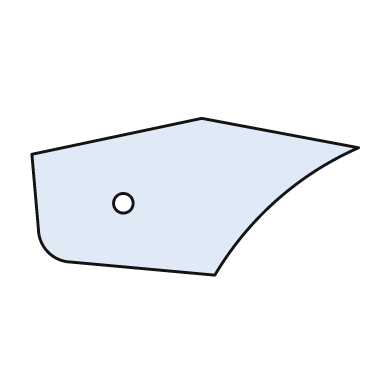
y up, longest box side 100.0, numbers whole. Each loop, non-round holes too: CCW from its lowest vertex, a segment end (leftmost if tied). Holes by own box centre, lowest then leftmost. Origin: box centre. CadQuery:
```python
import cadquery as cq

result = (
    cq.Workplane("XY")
    .moveTo(6.0, -24.0)
    .threePointArc((25.0, -1.0), (50.0, 15.0))
    .lineTo(2.0, 24.0)
    .lineTo(-50.0, 13.0)
    .lineTo(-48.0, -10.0)
    .threePointArc((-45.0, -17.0), (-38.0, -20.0))
    .close()
    .moveTo(-22.0, -2.0)
    .circle(3.0)
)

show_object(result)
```